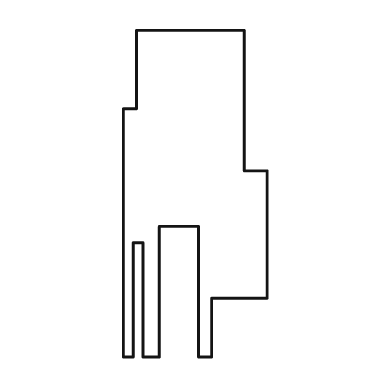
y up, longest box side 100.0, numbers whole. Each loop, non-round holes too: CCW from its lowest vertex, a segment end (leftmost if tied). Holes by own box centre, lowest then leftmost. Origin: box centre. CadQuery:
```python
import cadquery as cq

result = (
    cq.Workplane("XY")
    .moveTo(-22.0, -50.0)
    .lineTo(-19.0, -50.0)
    .lineTo(-19.0, -15.0)
    .lineTo(-16.0, -15.0)
    .lineTo(-16.0, -50.0)
    .lineTo(-11.0, -50.0)
    .lineTo(-11.0, -10.0)
    .lineTo(1.0, -10.0)
    .lineTo(1.0, -50.0)
    .lineTo(5.0, -50.0)
    .lineTo(5.0, -32.0)
    .lineTo(22.0, -32.0)
    .lineTo(22.0, 7.0)
    .lineTo(15.0, 7.0)
    .lineTo(15.0, 50.0)
    .lineTo(-18.0, 50.0)
    .lineTo(-18.0, 26.0)
    .lineTo(-22.0, 26.0)
    .close()
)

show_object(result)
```